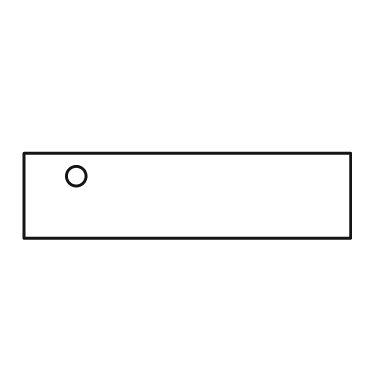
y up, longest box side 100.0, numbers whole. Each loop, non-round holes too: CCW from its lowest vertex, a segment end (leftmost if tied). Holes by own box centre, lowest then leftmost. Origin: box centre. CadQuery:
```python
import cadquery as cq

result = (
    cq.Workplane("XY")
    .moveTo(-50.0, -13.0)
    .lineTo(50.0, -13.0)
    .lineTo(50.0, 13.0)
    .lineTo(-50.0, 13.0)
    .close()
    .moveTo(-34.0, 6.0)
    .circle(3.0)
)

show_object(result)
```